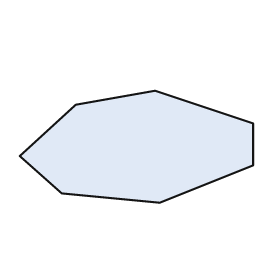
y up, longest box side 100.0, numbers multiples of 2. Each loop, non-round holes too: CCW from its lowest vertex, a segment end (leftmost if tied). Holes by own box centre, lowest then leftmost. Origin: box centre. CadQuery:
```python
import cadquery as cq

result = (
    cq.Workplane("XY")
    .moveTo(10.0, -24.0)
    .lineTo(50.0, -8.0)
    .lineTo(50.0, 10.0)
    .lineTo(8.0, 24.0)
    .lineTo(-26.0, 18.0)
    .lineTo(-50.0, -4.0)
    .lineTo(-32.0, -20.0)
    .close()
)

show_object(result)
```